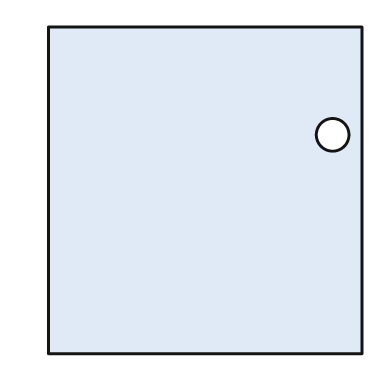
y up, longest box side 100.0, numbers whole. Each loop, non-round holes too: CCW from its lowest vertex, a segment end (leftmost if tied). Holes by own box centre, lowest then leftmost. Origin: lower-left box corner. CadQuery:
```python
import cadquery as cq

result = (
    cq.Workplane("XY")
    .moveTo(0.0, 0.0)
    .lineTo(96.0, 0.0)
    .lineTo(96.0, 100.0)
    .lineTo(0.0, 100.0)
    .close()
    .moveTo(87.0, 67.0)
    .circle(5.0)
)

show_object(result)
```